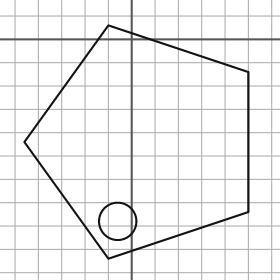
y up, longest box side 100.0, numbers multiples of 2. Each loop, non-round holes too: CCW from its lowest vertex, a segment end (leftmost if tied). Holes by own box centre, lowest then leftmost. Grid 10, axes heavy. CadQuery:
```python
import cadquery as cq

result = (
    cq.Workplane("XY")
    .moveTo(-10.0, -94.0)
    .lineTo(50.0, -74.0)
    .lineTo(50.0, -14.0)
    .lineTo(-10.0, 6.0)
    .lineTo(-46.0, -44.0)
    .close()
    .moveTo(-6.0, -78.0)
    .circle(8.0)
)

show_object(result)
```